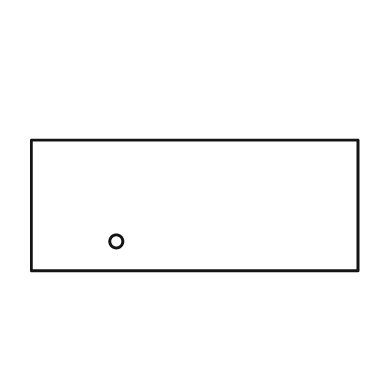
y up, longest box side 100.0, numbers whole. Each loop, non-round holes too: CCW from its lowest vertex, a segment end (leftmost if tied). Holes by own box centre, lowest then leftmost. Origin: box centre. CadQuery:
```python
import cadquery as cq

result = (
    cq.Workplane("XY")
    .moveTo(-50.0, -20.0)
    .lineTo(50.0, -20.0)
    .lineTo(50.0, 20.0)
    .lineTo(-50.0, 20.0)
    .close()
    .moveTo(-24.0, -11.0)
    .circle(2.0)
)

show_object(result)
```